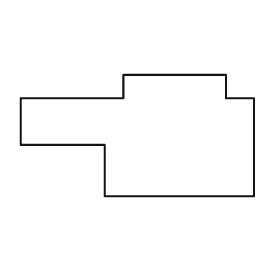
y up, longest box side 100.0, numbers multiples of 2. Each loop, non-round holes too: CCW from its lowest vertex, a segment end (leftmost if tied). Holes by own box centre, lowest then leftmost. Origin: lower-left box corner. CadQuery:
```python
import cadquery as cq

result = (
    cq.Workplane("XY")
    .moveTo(36.0, 0.0)
    .lineTo(100.0, 0.0)
    .lineTo(100.0, 42.0)
    .lineTo(88.0, 42.0)
    .lineTo(88.0, 52.0)
    .lineTo(44.0, 52.0)
    .lineTo(44.0, 42.0)
    .lineTo(0.0, 42.0)
    .lineTo(0.0, 22.0)
    .lineTo(36.0, 22.0)
    .close()
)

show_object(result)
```